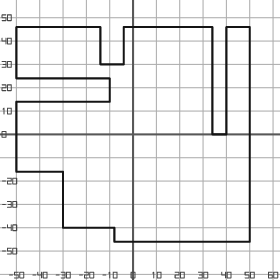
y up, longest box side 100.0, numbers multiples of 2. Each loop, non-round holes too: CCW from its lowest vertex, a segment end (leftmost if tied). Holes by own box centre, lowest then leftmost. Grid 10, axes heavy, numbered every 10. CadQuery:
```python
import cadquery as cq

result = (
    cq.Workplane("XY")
    .moveTo(-8.0, -46.0)
    .lineTo(50.0, -46.0)
    .lineTo(50.0, 46.0)
    .lineTo(40.0, 46.0)
    .lineTo(40.0, 0.0)
    .lineTo(34.0, 0.0)
    .lineTo(34.0, 46.0)
    .lineTo(-4.0, 46.0)
    .lineTo(-4.0, 30.0)
    .lineTo(-14.0, 30.0)
    .lineTo(-14.0, 46.0)
    .lineTo(-50.0, 46.0)
    .lineTo(-50.0, 24.0)
    .lineTo(-10.0, 24.0)
    .lineTo(-10.0, 14.0)
    .lineTo(-50.0, 14.0)
    .lineTo(-50.0, -16.0)
    .lineTo(-30.0, -16.0)
    .lineTo(-30.0, -40.0)
    .lineTo(-8.0, -40.0)
    .close()
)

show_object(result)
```